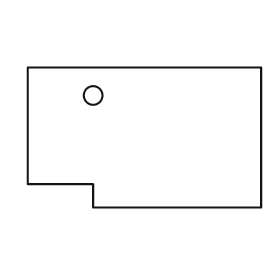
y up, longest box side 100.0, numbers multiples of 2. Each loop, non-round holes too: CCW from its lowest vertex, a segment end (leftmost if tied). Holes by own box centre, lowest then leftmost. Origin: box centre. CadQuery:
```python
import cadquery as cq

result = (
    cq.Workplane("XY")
    .moveTo(-22.0, -30.0)
    .lineTo(50.0, -30.0)
    .lineTo(50.0, 30.0)
    .lineTo(-50.0, 30.0)
    .lineTo(-50.0, -20.0)
    .lineTo(-22.0, -20.0)
    .close()
    .moveTo(-22.0, 18.0)
    .circle(4.0)
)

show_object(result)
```